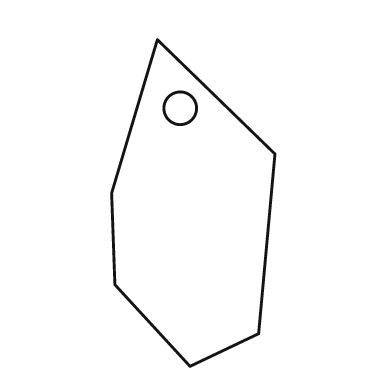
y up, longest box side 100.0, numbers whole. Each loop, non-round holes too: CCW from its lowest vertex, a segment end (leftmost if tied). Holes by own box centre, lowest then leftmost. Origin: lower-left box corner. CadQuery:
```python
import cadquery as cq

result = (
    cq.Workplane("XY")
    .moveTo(24.0, 0.0)
    .lineTo(45.0, 10.0)
    .lineTo(50.0, 65.0)
    .lineTo(14.0, 100.0)
    .lineTo(0.0, 53.0)
    .lineTo(1.0, 25.0)
    .close()
    .moveTo(21.0, 79.0)
    .circle(5.0)
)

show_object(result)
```